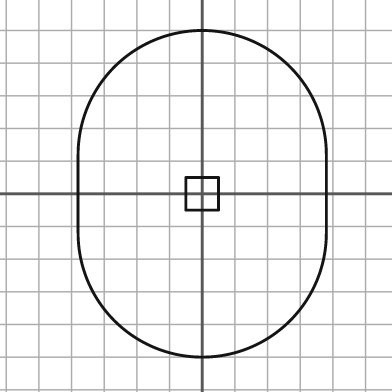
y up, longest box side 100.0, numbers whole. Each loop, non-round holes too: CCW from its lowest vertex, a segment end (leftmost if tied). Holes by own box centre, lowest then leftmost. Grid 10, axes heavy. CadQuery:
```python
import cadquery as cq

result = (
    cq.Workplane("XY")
    .moveTo(-38.0, -12.0)
    .threePointArc((0.0, -50.0), (38.0, -12.0))
    .lineTo(38.0, 12.0)
    .threePointArc((0.0, 50.0), (-38.0, 12.0))
    .close()
    .moveTo(-5.0, -5.0)
    .lineTo(5.0, -5.0)
    .lineTo(5.0, 5.0)
    .lineTo(-5.0, 5.0)
    .close()
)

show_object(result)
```